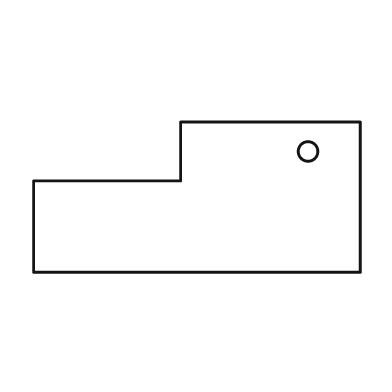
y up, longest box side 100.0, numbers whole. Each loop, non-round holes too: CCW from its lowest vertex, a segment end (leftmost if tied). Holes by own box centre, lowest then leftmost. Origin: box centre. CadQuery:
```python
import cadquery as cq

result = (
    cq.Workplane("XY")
    .moveTo(-50.0, -23.0)
    .lineTo(50.0, -23.0)
    .lineTo(50.0, 23.0)
    .lineTo(-5.0, 23.0)
    .lineTo(-5.0, 5.0)
    .lineTo(-50.0, 5.0)
    .close()
    .moveTo(34.0, 14.0)
    .circle(3.0)
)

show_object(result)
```